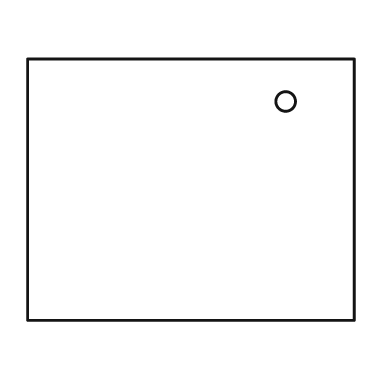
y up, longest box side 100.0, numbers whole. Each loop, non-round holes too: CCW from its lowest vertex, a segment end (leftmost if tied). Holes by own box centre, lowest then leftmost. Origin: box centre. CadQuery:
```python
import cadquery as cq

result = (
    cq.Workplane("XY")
    .moveTo(-50.0, -40.0)
    .lineTo(50.0, -40.0)
    .lineTo(50.0, 40.0)
    .lineTo(-50.0, 40.0)
    .close()
    .moveTo(29.0, 27.0)
    .circle(3.0)
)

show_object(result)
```